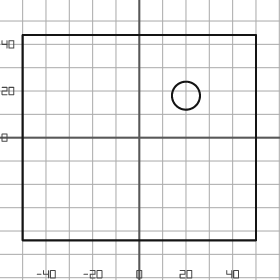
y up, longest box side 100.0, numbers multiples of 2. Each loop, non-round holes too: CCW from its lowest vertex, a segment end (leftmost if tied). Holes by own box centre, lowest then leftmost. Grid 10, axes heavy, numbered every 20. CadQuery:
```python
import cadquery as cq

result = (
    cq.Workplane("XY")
    .moveTo(-50.0, -44.0)
    .lineTo(50.0, -44.0)
    .lineTo(50.0, 44.0)
    .lineTo(-50.0, 44.0)
    .close()
    .moveTo(20.0, 18.0)
    .circle(6.0)
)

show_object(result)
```